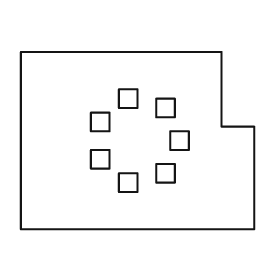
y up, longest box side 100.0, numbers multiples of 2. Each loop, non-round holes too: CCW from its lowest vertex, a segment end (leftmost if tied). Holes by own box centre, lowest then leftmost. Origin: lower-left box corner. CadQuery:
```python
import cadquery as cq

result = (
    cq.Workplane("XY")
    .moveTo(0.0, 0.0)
    .lineTo(100.0, 0.0)
    .lineTo(100.0, 44.0)
    .lineTo(86.0, 44.0)
    .lineTo(86.0, 76.0)
    .lineTo(0.0, 76.0)
    .close()
    .moveTo(42.0, 16.0)
    .lineTo(50.0, 16.0)
    .lineTo(50.0, 24.0)
    .lineTo(42.0, 24.0)
    .close()
    .moveTo(58.0, 20.0)
    .lineTo(66.0, 20.0)
    .lineTo(66.0, 28.0)
    .lineTo(58.0, 28.0)
    .close()
    .moveTo(30.0, 26.0)
    .lineTo(38.0, 26.0)
    .lineTo(38.0, 34.0)
    .lineTo(30.0, 34.0)
    .close()
    .moveTo(64.0, 34.0)
    .lineTo(72.0, 34.0)
    .lineTo(72.0, 42.0)
    .lineTo(64.0, 42.0)
    .close()
    .moveTo(30.0, 42.0)
    .lineTo(38.0, 42.0)
    .lineTo(38.0, 50.0)
    .lineTo(30.0, 50.0)
    .close()
    .moveTo(58.0, 48.0)
    .lineTo(66.0, 48.0)
    .lineTo(66.0, 56.0)
    .lineTo(58.0, 56.0)
    .close()
    .moveTo(42.0, 52.0)
    .lineTo(50.0, 52.0)
    .lineTo(50.0, 60.0)
    .lineTo(42.0, 60.0)
    .close()
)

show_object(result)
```